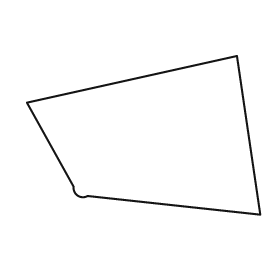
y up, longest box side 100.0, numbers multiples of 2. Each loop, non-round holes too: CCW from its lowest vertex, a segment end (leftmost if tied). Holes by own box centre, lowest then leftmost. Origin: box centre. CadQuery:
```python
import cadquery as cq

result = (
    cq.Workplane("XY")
    .moveTo(50.0, -34.0)
    .lineTo(40.0, 34.0)
    .lineTo(-50.0, 14.0)
    .lineTo(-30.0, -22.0)
    .threePointArc((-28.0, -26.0), (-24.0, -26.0))
    .close()
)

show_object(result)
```